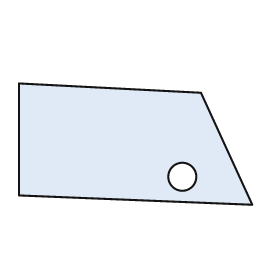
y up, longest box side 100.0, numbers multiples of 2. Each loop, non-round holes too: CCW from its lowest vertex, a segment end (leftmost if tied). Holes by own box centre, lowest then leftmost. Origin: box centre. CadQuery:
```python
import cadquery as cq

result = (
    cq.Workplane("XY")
    .moveTo(50.0, -26.0)
    .lineTo(28.0, 22.0)
    .lineTo(-50.0, 26.0)
    .lineTo(-50.0, -22.0)
    .close()
    .moveTo(20.0, -14.0)
    .circle(6.0)
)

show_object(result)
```